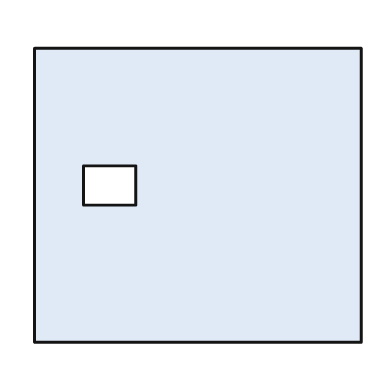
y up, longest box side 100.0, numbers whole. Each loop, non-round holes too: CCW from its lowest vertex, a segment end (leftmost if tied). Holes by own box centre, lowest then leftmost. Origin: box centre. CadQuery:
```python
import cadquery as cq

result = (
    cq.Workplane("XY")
    .moveTo(-50.0, -45.0)
    .lineTo(50.0, -45.0)
    .lineTo(50.0, 45.0)
    .lineTo(-50.0, 45.0)
    .close()
    .moveTo(-35.0, -3.0)
    .lineTo(-19.0, -3.0)
    .lineTo(-19.0, 9.0)
    .lineTo(-35.0, 9.0)
    .close()
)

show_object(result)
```